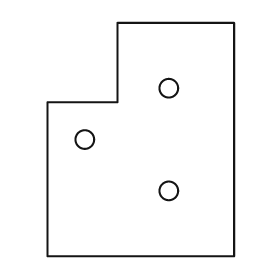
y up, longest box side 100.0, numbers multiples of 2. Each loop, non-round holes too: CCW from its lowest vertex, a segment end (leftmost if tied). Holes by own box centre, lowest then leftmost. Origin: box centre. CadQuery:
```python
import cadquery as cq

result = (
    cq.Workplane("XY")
    .moveTo(-40.0, -50.0)
    .lineTo(40.0, -50.0)
    .lineTo(40.0, 50.0)
    .lineTo(-10.0, 50.0)
    .lineTo(-10.0, 16.0)
    .lineTo(-40.0, 16.0)
    .close()
    .moveTo(12.0, -22.0)
    .circle(4.0)
    .moveTo(-24.0, 0.0)
    .circle(4.0)
    .moveTo(12.0, 22.0)
    .circle(4.0)
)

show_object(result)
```